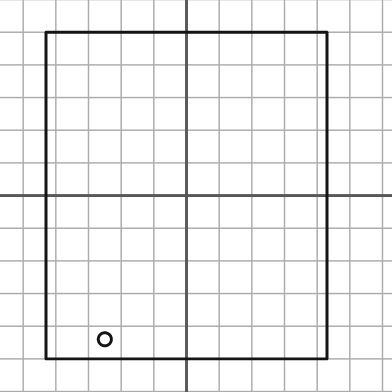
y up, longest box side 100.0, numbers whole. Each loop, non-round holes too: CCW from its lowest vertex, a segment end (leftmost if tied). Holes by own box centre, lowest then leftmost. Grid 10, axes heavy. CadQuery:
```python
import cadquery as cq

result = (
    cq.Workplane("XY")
    .moveTo(-43.0, -50.0)
    .lineTo(43.0, -50.0)
    .lineTo(43.0, 50.0)
    .lineTo(-43.0, 50.0)
    .close()
    .moveTo(-25.0, -44.0)
    .circle(2.0)
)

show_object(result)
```